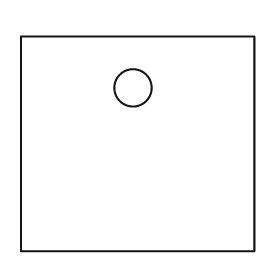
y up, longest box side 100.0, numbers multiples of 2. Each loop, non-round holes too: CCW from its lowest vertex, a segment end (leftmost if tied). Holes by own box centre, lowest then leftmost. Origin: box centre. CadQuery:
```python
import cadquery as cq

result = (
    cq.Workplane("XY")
    .moveTo(-50.0, -46.0)
    .lineTo(50.0, -46.0)
    .lineTo(50.0, 46.0)
    .lineTo(-50.0, 46.0)
    .close()
    .moveTo(-2.0, 24.0)
    .circle(8.0)
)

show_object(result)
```